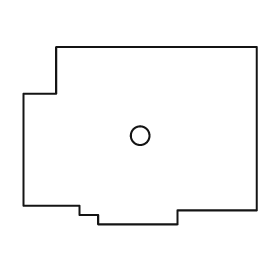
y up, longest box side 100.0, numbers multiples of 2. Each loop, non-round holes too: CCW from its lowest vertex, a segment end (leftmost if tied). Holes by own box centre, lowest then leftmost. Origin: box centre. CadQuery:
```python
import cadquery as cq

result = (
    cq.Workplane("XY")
    .moveTo(-18.0, -38.0)
    .lineTo(16.0, -38.0)
    .lineTo(16.0, -32.0)
    .lineTo(50.0, -32.0)
    .lineTo(50.0, 38.0)
    .lineTo(-36.0, 38.0)
    .lineTo(-36.0, 18.0)
    .lineTo(-50.0, 18.0)
    .lineTo(-50.0, -30.0)
    .lineTo(-26.0, -30.0)
    .lineTo(-26.0, -34.0)
    .lineTo(-18.0, -34.0)
    .close()
    .moveTo(0.0, 0.0)
    .circle(4.0)
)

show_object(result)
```